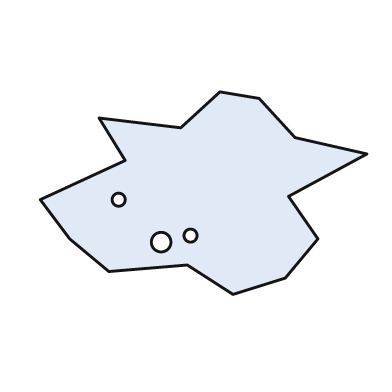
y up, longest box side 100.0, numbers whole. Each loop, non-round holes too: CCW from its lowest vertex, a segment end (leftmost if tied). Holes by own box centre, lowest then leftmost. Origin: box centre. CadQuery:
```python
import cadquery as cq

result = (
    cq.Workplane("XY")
    .moveTo(9.0, -31.0)
    .lineTo(25.0, -26.0)
    .lineTo(35.0, -14.0)
    .lineTo(26.0, -1.0)
    .lineTo(50.0, 12.0)
    .lineTo(28.0, 17.0)
    .lineTo(17.0, 29.0)
    .lineTo(5.0, 31.0)
    .lineTo(-7.0, 20.0)
    .lineTo(-32.0, 23.0)
    .lineTo(-24.0, 10.0)
    .lineTo(-50.0, -2.0)
    .lineTo(-41.0, -14.0)
    .lineTo(-29.0, -24.0)
    .lineTo(-5.0, -22.0)
    .close()
    .moveTo(-13.0, -15.0)
    .circle(3.0)
    .moveTo(-4.0, -13.0)
    .circle(2.0)
    .moveTo(-26.0, -2.0)
    .circle(2.0)
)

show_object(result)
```